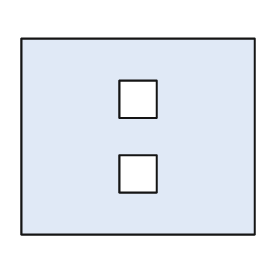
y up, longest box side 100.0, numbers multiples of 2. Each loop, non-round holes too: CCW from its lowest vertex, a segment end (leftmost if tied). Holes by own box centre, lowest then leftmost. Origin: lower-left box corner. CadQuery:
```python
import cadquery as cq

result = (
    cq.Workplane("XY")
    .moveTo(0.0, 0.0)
    .lineTo(100.0, 0.0)
    .lineTo(100.0, 84.0)
    .lineTo(0.0, 84.0)
    .close()
    .moveTo(42.0, 18.0)
    .lineTo(58.0, 18.0)
    .lineTo(58.0, 34.0)
    .lineTo(42.0, 34.0)
    .close()
    .moveTo(42.0, 50.0)
    .lineTo(58.0, 50.0)
    .lineTo(58.0, 66.0)
    .lineTo(42.0, 66.0)
    .close()
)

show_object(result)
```